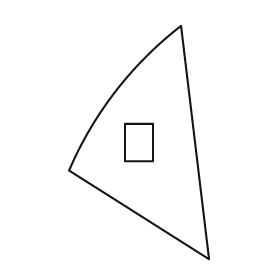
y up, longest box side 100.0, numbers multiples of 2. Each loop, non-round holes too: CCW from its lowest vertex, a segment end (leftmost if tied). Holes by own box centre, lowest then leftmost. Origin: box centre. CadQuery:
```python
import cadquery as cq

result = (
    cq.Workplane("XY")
    .moveTo(30.0, -50.0)
    .lineTo(18.0, 50.0)
    .threePointArc((-10.0, 22.0), (-30.0, -12.0))
    .close()
    .moveTo(-6.0, -8.0)
    .lineTo(6.0, -8.0)
    .lineTo(6.0, 8.0)
    .lineTo(-6.0, 8.0)
    .close()
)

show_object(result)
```